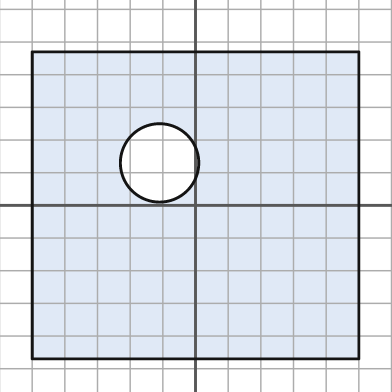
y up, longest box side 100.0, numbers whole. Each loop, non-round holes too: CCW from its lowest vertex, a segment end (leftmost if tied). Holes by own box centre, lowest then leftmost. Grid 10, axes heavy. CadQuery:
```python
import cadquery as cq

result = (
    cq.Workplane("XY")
    .moveTo(-50.0, -47.0)
    .lineTo(50.0, -47.0)
    .lineTo(50.0, 47.0)
    .lineTo(-50.0, 47.0)
    .close()
    .moveTo(-11.0, 13.0)
    .circle(12.0)
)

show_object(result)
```